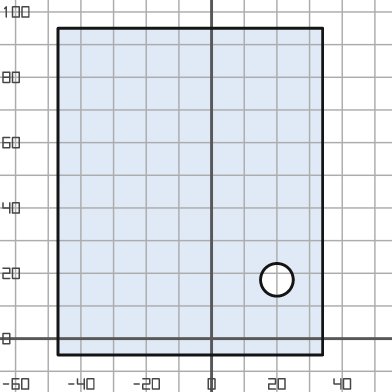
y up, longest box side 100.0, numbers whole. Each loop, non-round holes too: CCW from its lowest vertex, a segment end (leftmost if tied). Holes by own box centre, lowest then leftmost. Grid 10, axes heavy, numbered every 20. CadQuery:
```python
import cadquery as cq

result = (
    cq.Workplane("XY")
    .moveTo(-47.0, -5.0)
    .lineTo(34.0, -5.0)
    .lineTo(34.0, 95.0)
    .lineTo(-47.0, 95.0)
    .close()
    .moveTo(20.0, 18.0)
    .circle(5.0)
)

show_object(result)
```